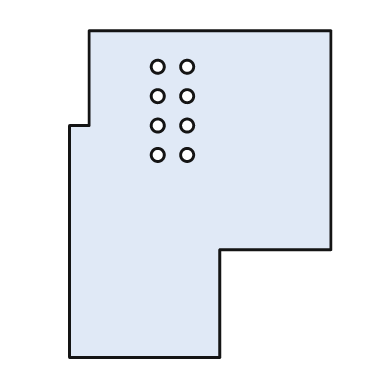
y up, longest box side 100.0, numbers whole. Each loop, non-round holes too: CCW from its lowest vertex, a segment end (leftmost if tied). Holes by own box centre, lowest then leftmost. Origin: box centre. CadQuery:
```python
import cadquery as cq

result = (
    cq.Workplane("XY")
    .moveTo(-40.0, -50.0)
    .lineTo(6.0, -50.0)
    .lineTo(6.0, -17.0)
    .lineTo(40.0, -17.0)
    .lineTo(40.0, 50.0)
    .lineTo(-34.0, 50.0)
    .lineTo(-34.0, 21.0)
    .lineTo(-40.0, 21.0)
    .close()
    .moveTo(-13.0, 12.0)
    .circle(2.0)
    .moveTo(-4.0, 12.0)
    .circle(2.0)
    .moveTo(-13.0, 21.0)
    .circle(2.0)
    .moveTo(-4.0, 21.0)
    .circle(2.0)
    .moveTo(-13.0, 30.0)
    .circle(2.0)
    .moveTo(-4.0, 30.0)
    .circle(2.0)
    .moveTo(-13.0, 39.0)
    .circle(2.0)
    .moveTo(-4.0, 39.0)
    .circle(2.0)
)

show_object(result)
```